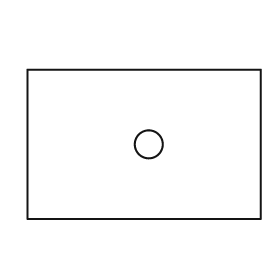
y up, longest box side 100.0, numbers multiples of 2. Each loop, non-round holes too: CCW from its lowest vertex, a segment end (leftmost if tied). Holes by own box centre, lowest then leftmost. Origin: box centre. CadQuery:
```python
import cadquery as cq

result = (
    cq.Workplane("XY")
    .moveTo(-50.0, -32.0)
    .lineTo(50.0, -32.0)
    .lineTo(50.0, 32.0)
    .lineTo(-50.0, 32.0)
    .close()
    .moveTo(2.0, 0.0)
    .circle(6.0)
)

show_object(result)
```